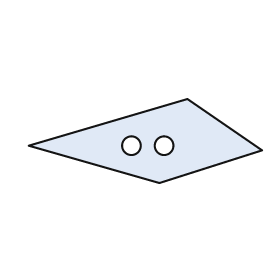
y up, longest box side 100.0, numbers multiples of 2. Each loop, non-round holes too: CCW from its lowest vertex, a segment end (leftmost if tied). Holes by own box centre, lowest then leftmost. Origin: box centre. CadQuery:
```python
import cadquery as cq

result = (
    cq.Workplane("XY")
    .moveTo(6.0, -18.0)
    .lineTo(50.0, -4.0)
    .lineTo(18.0, 18.0)
    .lineTo(-50.0, -2.0)
    .close()
    .moveTo(-6.0, -2.0)
    .circle(4.0)
    .moveTo(8.0, -2.0)
    .circle(4.0)
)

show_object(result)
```